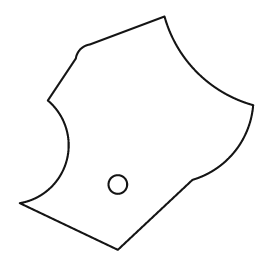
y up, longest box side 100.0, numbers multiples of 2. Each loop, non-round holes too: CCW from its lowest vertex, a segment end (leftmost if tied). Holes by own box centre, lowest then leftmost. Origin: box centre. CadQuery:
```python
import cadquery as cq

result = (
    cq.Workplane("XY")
    .moveTo(-8.0, -50.0)
    .lineTo(24.0, -20.0)
    .threePointArc((42.0, -8.0), (50.0, 12.0))
    .threePointArc((26.0, 26.0), (12.0, 50.0))
    .lineTo(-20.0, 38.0)
    .threePointArc((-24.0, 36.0), (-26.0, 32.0))
    .lineTo(-38.0, 14.0)
    .threePointArc((-30.0, -12.0), (-50.0, -30.0))
    .close()
    .moveTo(-8.0, -22.0)
    .circle(4.0)
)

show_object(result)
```